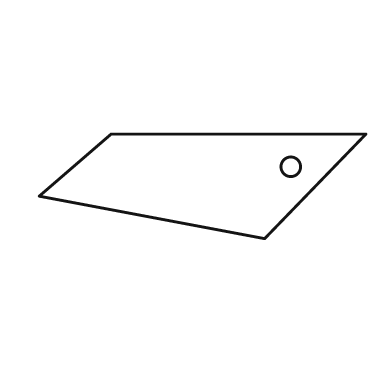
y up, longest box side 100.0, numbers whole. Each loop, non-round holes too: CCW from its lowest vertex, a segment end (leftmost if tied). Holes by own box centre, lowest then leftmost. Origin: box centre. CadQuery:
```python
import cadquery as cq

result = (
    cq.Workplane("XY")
    .moveTo(19.0, -16.0)
    .lineTo(50.0, 16.0)
    .lineTo(-28.0, 16.0)
    .lineTo(-50.0, -3.0)
    .close()
    .moveTo(27.0, 6.0)
    .circle(3.0)
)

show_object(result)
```